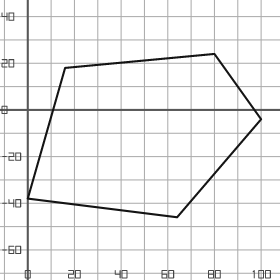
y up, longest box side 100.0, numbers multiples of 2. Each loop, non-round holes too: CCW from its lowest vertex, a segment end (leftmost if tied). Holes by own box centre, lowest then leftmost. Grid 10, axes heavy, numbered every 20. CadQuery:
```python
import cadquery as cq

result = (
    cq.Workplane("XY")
    .moveTo(64.0, -46.0)
    .lineTo(100.0, -4.0)
    .lineTo(80.0, 24.0)
    .lineTo(16.0, 18.0)
    .lineTo(0.0, -38.0)
    .close()
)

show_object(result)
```